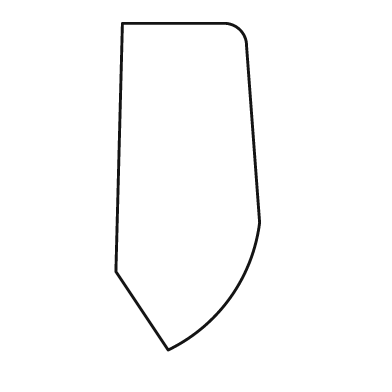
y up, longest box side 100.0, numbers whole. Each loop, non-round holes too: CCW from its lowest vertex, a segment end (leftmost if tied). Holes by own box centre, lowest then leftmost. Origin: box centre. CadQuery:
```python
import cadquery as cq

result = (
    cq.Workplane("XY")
    .moveTo(-6.0, -50.0)
    .threePointArc((13.0, -34.0), (22.0, -11.0))
    .lineTo(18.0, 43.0)
    .threePointArc((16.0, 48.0), (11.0, 50.0))
    .lineTo(-20.0, 50.0)
    .lineTo(-22.0, -26.0)
    .close()
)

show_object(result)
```